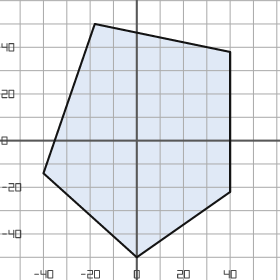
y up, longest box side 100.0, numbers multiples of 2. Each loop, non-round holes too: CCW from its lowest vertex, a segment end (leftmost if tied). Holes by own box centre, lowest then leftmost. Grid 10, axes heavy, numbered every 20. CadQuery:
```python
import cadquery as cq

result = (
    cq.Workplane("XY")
    .moveTo(0.0, -50.0)
    .lineTo(40.0, -22.0)
    .lineTo(40.0, 38.0)
    .lineTo(-18.0, 50.0)
    .lineTo(-40.0, -14.0)
    .close()
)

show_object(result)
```